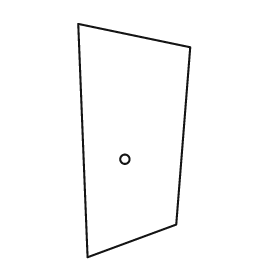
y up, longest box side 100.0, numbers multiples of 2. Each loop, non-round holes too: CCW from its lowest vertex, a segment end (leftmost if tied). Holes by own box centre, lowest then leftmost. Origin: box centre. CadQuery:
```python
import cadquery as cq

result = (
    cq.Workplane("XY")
    .moveTo(-20.0, -50.0)
    .lineTo(18.0, -36.0)
    .lineTo(24.0, 40.0)
    .lineTo(-24.0, 50.0)
    .close()
    .moveTo(-4.0, -8.0)
    .circle(2.0)
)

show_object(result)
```